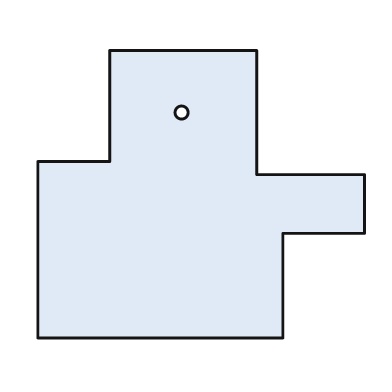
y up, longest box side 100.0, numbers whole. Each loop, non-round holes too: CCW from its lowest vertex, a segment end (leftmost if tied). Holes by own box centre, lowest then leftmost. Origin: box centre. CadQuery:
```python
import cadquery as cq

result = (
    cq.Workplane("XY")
    .moveTo(-50.0, -44.0)
    .lineTo(25.0, -44.0)
    .lineTo(25.0, -12.0)
    .lineTo(50.0, -12.0)
    .lineTo(50.0, 6.0)
    .lineTo(17.0, 6.0)
    .lineTo(17.0, 44.0)
    .lineTo(-28.0, 44.0)
    .lineTo(-28.0, 10.0)
    .lineTo(-50.0, 10.0)
    .close()
    .moveTo(-6.0, 25.0)
    .circle(2.0)
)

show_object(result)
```